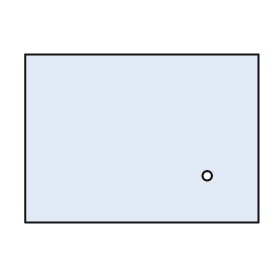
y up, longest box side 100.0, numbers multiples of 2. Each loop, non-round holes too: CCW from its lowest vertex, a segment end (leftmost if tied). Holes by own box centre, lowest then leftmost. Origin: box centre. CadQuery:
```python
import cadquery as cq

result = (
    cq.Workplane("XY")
    .moveTo(-50.0, -36.0)
    .lineTo(50.0, -36.0)
    .lineTo(50.0, 36.0)
    .lineTo(-50.0, 36.0)
    .close()
    .moveTo(28.0, -16.0)
    .circle(2.0)
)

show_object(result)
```